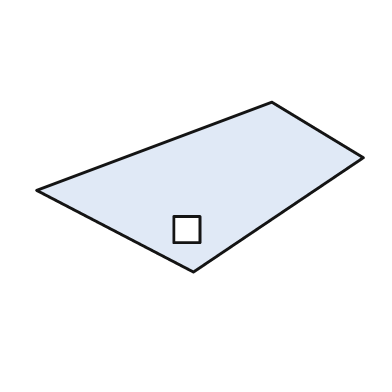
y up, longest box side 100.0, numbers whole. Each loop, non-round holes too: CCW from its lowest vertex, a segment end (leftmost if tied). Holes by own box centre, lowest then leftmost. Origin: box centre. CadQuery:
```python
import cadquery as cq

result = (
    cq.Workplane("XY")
    .moveTo(-2.0, -26.0)
    .lineTo(50.0, 9.0)
    .lineTo(22.0, 26.0)
    .lineTo(-50.0, -1.0)
    .close()
    .moveTo(-8.0, -17.0)
    .lineTo(0.0, -17.0)
    .lineTo(0.0, -9.0)
    .lineTo(-8.0, -9.0)
    .close()
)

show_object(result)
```